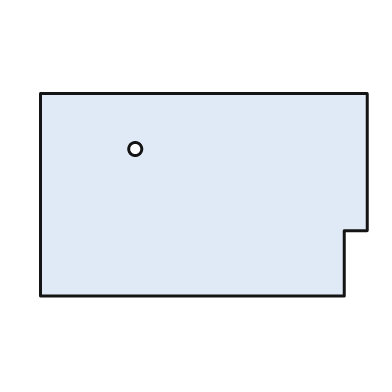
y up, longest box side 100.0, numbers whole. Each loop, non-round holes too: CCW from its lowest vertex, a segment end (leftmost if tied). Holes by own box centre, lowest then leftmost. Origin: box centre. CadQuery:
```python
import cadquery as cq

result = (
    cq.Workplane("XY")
    .moveTo(-50.0, -31.0)
    .lineTo(43.0, -31.0)
    .lineTo(43.0, -11.0)
    .lineTo(50.0, -11.0)
    .lineTo(50.0, 31.0)
    .lineTo(-50.0, 31.0)
    .close()
    .moveTo(-21.0, 14.0)
    .circle(2.0)
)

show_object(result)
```